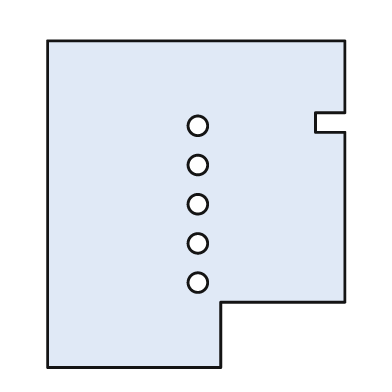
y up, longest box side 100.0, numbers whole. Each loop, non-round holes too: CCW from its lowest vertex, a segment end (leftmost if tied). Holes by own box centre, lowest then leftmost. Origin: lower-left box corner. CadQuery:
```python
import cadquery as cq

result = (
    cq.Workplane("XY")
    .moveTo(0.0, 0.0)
    .lineTo(53.0, 0.0)
    .lineTo(53.0, 20.0)
    .lineTo(91.0, 20.0)
    .lineTo(91.0, 72.0)
    .lineTo(82.0, 72.0)
    .lineTo(82.0, 78.0)
    .lineTo(91.0, 78.0)
    .lineTo(91.0, 100.0)
    .lineTo(0.0, 100.0)
    .close()
    .moveTo(46.0, 26.0)
    .circle(3.0)
    .moveTo(46.0, 38.0)
    .circle(3.0)
    .moveTo(46.0, 50.0)
    .circle(3.0)
    .moveTo(46.0, 62.0)
    .circle(3.0)
    .moveTo(46.0, 74.0)
    .circle(3.0)
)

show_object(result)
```